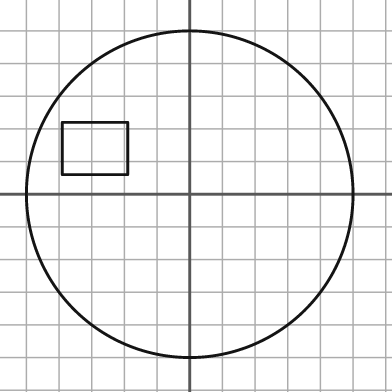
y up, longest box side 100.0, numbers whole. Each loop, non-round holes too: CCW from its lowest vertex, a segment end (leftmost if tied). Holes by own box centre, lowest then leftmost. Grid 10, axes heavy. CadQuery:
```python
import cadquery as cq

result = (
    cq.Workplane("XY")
    .moveTo(0.0, 0.0)
    .circle(50.0)
    .moveTo(-39.0, 6.0)
    .lineTo(-19.0, 6.0)
    .lineTo(-19.0, 22.0)
    .lineTo(-39.0, 22.0)
    .close()
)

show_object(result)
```